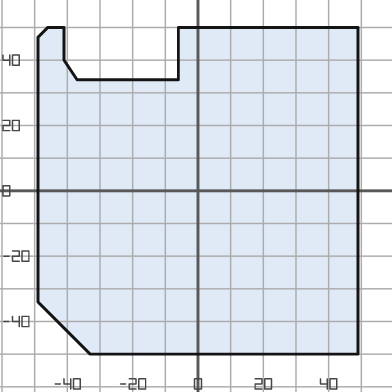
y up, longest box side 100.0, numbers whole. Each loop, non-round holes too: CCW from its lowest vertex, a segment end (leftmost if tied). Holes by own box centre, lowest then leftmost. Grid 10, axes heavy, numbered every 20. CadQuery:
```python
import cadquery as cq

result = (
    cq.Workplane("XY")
    .moveTo(-33.0, -50.0)
    .lineTo(49.0, -50.0)
    .lineTo(49.0, 50.0)
    .lineTo(-6.0, 50.0)
    .lineTo(-6.0, 34.0)
    .lineTo(-37.0, 34.0)
    .lineTo(-41.0, 40.0)
    .lineTo(-41.0, 50.0)
    .lineTo(-46.0, 50.0)
    .lineTo(-49.0, 47.0)
    .lineTo(-49.0, -34.0)
    .close()
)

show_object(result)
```